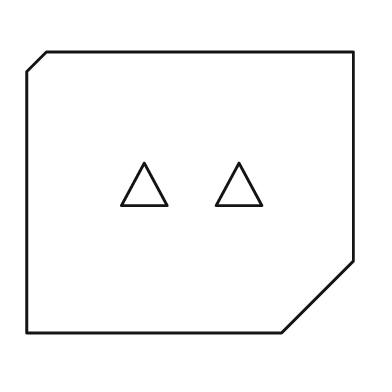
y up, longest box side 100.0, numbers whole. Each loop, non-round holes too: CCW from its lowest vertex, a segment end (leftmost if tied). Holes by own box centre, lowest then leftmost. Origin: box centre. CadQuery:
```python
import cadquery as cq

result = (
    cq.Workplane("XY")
    .moveTo(-50.0, -43.0)
    .lineTo(28.0, -43.0)
    .lineTo(50.0, -21.0)
    .lineTo(50.0, 43.0)
    .lineTo(-44.0, 43.0)
    .lineTo(-50.0, 37.0)
    .close()
    .moveTo(-21.0, -4.0)
    .lineTo(-7.0, -4.0)
    .lineTo(-14.0, 9.0)
    .close()
    .moveTo(8.0, -4.0)
    .lineTo(22.0, -4.0)
    .lineTo(15.0, 9.0)
    .close()
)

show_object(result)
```